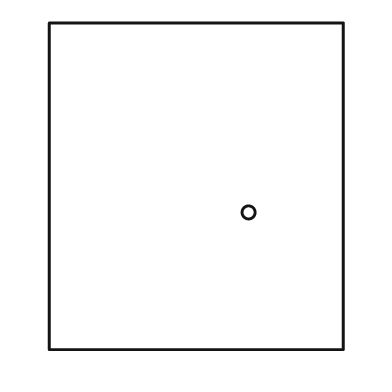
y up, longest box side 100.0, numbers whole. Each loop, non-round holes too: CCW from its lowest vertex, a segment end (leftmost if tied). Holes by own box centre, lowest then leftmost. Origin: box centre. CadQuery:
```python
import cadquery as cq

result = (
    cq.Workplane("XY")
    .moveTo(-45.0, -50.0)
    .lineTo(45.0, -50.0)
    .lineTo(45.0, 50.0)
    .lineTo(-45.0, 50.0)
    .close()
    .moveTo(16.0, -8.0)
    .circle(2.0)
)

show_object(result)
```